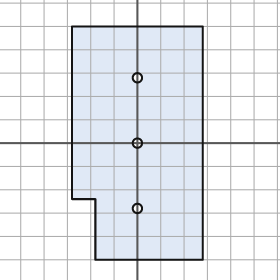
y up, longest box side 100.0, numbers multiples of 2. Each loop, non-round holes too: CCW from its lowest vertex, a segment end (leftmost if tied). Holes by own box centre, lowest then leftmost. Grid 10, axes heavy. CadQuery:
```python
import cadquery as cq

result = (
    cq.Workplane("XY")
    .moveTo(-18.0, -50.0)
    .lineTo(28.0, -50.0)
    .lineTo(28.0, 50.0)
    .lineTo(-28.0, 50.0)
    .lineTo(-28.0, -24.0)
    .lineTo(-18.0, -24.0)
    .close()
    .moveTo(0.0, -28.0)
    .circle(2.0)
    .moveTo(0.0, 0.0)
    .circle(2.0)
    .moveTo(0.0, 28.0)
    .circle(2.0)
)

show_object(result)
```